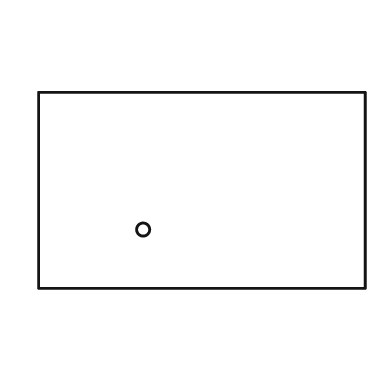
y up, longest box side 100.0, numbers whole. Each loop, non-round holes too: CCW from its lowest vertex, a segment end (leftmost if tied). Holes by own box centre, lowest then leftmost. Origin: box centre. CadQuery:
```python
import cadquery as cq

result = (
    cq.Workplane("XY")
    .moveTo(-50.0, -30.0)
    .lineTo(50.0, -30.0)
    .lineTo(50.0, 30.0)
    .lineTo(-50.0, 30.0)
    .close()
    .moveTo(-18.0, -12.0)
    .circle(2.0)
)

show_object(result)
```